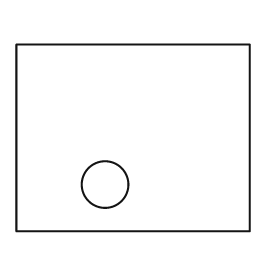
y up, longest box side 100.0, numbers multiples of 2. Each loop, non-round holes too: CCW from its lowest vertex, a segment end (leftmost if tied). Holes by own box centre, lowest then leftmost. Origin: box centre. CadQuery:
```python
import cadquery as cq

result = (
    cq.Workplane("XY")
    .moveTo(-50.0, -40.0)
    .lineTo(50.0, -40.0)
    .lineTo(50.0, 40.0)
    .lineTo(-50.0, 40.0)
    .close()
    .moveTo(-12.0, -20.0)
    .circle(10.0)
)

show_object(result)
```